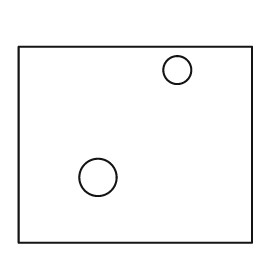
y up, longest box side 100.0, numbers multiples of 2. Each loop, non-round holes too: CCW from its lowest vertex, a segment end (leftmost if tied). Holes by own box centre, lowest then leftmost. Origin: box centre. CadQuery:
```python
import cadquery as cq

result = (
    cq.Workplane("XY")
    .moveTo(-50.0, -42.0)
    .lineTo(50.0, -42.0)
    .lineTo(50.0, 42.0)
    .lineTo(-50.0, 42.0)
    .close()
    .moveTo(-16.0, -14.0)
    .circle(8.0)
    .moveTo(18.0, 32.0)
    .circle(6.0)
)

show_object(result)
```